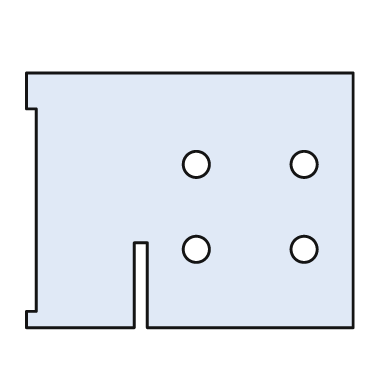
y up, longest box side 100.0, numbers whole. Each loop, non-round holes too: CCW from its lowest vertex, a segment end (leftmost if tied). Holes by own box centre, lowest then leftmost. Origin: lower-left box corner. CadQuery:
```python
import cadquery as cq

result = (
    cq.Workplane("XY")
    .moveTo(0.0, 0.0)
    .lineTo(33.0, 0.0)
    .lineTo(33.0, 26.0)
    .lineTo(37.0, 26.0)
    .lineTo(37.0, 0.0)
    .lineTo(100.0, 0.0)
    .lineTo(100.0, 78.0)
    .lineTo(0.0, 78.0)
    .lineTo(0.0, 67.0)
    .lineTo(3.0, 67.0)
    .lineTo(3.0, 5.0)
    .lineTo(0.0, 5.0)
    .close()
    .moveTo(52.0, 24.0)
    .circle(4.0)
    .moveTo(85.0, 24.0)
    .circle(4.0)
    .moveTo(52.0, 50.0)
    .circle(4.0)
    .moveTo(85.0, 50.0)
    .circle(4.0)
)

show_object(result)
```